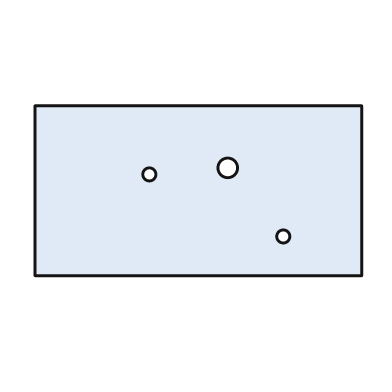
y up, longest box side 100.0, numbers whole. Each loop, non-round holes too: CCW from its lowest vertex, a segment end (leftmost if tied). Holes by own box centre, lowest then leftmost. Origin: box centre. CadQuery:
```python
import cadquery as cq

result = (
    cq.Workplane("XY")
    .moveTo(-50.0, -26.0)
    .lineTo(50.0, -26.0)
    .lineTo(50.0, 26.0)
    .lineTo(-50.0, 26.0)
    .close()
    .moveTo(26.0, -14.0)
    .circle(2.0)
    .moveTo(-15.0, 5.0)
    .circle(2.0)
    .moveTo(9.0, 7.0)
    .circle(3.0)
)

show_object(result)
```